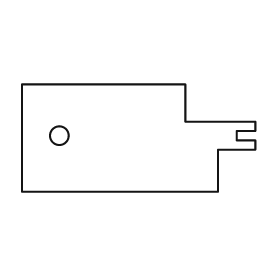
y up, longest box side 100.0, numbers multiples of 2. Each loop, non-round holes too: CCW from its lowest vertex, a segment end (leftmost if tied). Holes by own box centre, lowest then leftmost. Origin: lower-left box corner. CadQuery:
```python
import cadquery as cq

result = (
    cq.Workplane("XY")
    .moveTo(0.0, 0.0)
    .lineTo(84.0, 0.0)
    .lineTo(84.0, 18.0)
    .lineTo(100.0, 18.0)
    .lineTo(100.0, 22.0)
    .lineTo(92.0, 22.0)
    .lineTo(92.0, 26.0)
    .lineTo(100.0, 26.0)
    .lineTo(100.0, 30.0)
    .lineTo(70.0, 30.0)
    .lineTo(70.0, 46.0)
    .lineTo(0.0, 46.0)
    .close()
    .moveTo(16.0, 24.0)
    .circle(4.0)
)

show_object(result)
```